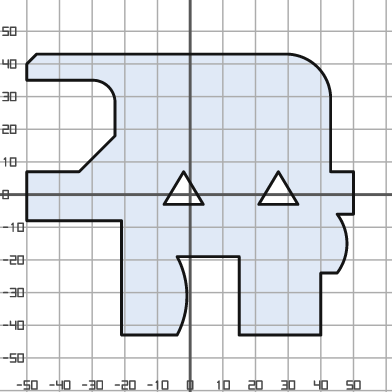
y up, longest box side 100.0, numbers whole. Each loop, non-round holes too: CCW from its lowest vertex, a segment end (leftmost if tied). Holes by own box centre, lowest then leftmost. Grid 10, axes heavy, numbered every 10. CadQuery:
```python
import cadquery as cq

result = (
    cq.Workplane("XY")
    .moveTo(-21.0, -43.0)
    .lineTo(-4.0, -43.0)
    .threePointArc((-1.0, -31.0), (-4.0, -19.0))
    .lineTo(15.0, -19.0)
    .lineTo(15.0, -43.0)
    .lineTo(40.0, -43.0)
    .lineTo(40.0, -24.0)
    .lineTo(45.0, -24.0)
    .threePointArc((48.0, -15.0), (45.0, -6.0))
    .lineTo(50.0, -6.0)
    .lineTo(50.0, 7.0)
    .lineTo(43.0, 7.0)
    .lineTo(43.0, 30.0)
    .threePointArc((39.0, 39.0), (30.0, 43.0))
    .lineTo(-47.0, 43.0)
    .lineTo(-50.0, 40.0)
    .lineTo(-50.0, 35.0)
    .lineTo(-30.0, 35.0)
    .threePointArc((-25.0, 33.0), (-23.0, 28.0))
    .lineTo(-23.0, 18.0)
    .lineTo(-34.0, 7.0)
    .lineTo(-50.0, 7.0)
    .lineTo(-50.0, -8.0)
    .lineTo(-21.0, -8.0)
    .close()
    .moveTo(-8.0, -3.0)
    .lineTo(4.0, -3.0)
    .lineTo(-2.0, 7.0)
    .close()
    .moveTo(21.0, -3.0)
    .lineTo(33.0, -3.0)
    .lineTo(27.0, 7.0)
    .close()
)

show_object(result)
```